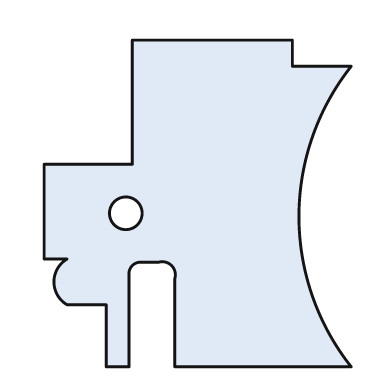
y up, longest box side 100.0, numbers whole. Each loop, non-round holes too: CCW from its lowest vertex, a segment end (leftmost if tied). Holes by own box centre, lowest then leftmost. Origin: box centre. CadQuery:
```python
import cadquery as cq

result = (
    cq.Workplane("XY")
    .moveTo(-28.0, -50.0)
    .lineTo(-21.0, -50.0)
    .lineTo(-21.0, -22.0)
    .threePointArc((-20.0, -19.0), (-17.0, -18.0))
    .lineTo(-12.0, -18.0)
    .threePointArc((-8.0, -19.0), (-7.0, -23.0))
    .lineTo(-7.0, -50.0)
    .lineTo(47.0, -50.0)
    .threePointArc((31.0, -4.0), (47.0, 42.0))
    .lineTo(29.0, 42.0)
    .lineTo(29.0, 50.0)
    .lineTo(-20.0, 50.0)
    .lineTo(-20.0, 12.0)
    .lineTo(-47.0, 12.0)
    .lineTo(-47.0, -17.0)
    .lineTo(-40.0, -17.0)
    .threePointArc((-44.0, -24.0), (-40.0, -31.0))
    .lineTo(-28.0, -31.0)
    .close()
    .moveTo(-22.0, -3.0)
    .circle(5.0)
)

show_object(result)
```